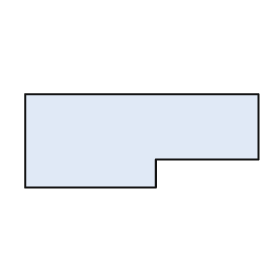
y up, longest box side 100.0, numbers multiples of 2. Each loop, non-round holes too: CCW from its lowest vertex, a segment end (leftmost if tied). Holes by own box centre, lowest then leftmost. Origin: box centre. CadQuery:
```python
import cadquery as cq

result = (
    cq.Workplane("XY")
    .moveTo(-50.0, -20.0)
    .lineTo(6.0, -20.0)
    .lineTo(6.0, -8.0)
    .lineTo(50.0, -8.0)
    .lineTo(50.0, 20.0)
    .lineTo(-50.0, 20.0)
    .close()
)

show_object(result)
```